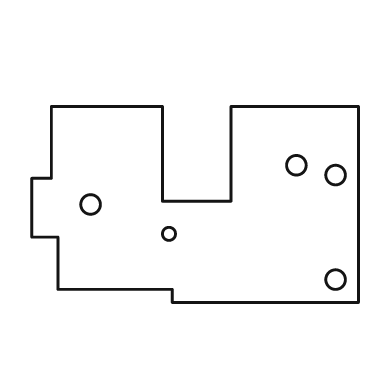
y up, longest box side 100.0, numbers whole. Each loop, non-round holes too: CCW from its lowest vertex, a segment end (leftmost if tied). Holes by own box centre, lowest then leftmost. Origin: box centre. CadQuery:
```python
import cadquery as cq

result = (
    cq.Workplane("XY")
    .moveTo(-7.0, -30.0)
    .lineTo(50.0, -30.0)
    .lineTo(50.0, 30.0)
    .lineTo(11.0, 30.0)
    .lineTo(11.0, 1.0)
    .lineTo(-10.0, 1.0)
    .lineTo(-10.0, 30.0)
    .lineTo(-44.0, 30.0)
    .lineTo(-44.0, 8.0)
    .lineTo(-50.0, 8.0)
    .lineTo(-50.0, -10.0)
    .lineTo(-42.0, -10.0)
    .lineTo(-42.0, -26.0)
    .lineTo(-7.0, -26.0)
    .close()
    .moveTo(43.0, -23.0)
    .circle(3.0)
    .moveTo(-8.0, -9.0)
    .circle(2.0)
    .moveTo(-32.0, 0.0)
    .circle(3.0)
    .moveTo(43.0, 9.0)
    .circle(3.0)
    .moveTo(31.0, 12.0)
    .circle(3.0)
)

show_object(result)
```